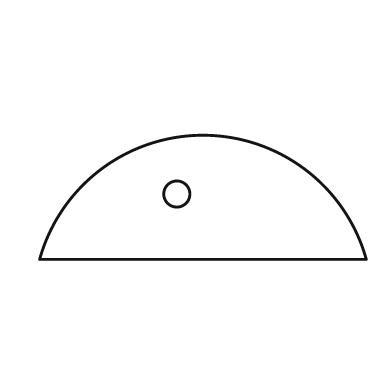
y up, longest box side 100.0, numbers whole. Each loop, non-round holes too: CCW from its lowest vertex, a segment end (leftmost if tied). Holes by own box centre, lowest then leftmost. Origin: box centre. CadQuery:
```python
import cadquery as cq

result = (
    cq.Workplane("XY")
    .moveTo(-50.0, -19.0)
    .lineTo(50.0, -19.0)
    .threePointArc((0.0, 19.0), (-50.0, -19.0))
    .close()
    .moveTo(-8.0, 1.0)
    .circle(4.0)
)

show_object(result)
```